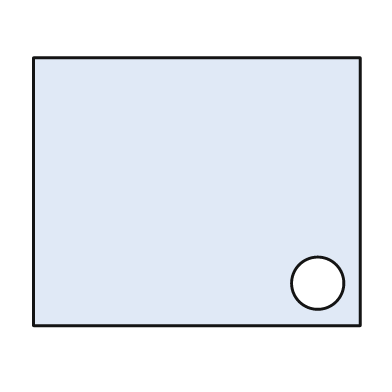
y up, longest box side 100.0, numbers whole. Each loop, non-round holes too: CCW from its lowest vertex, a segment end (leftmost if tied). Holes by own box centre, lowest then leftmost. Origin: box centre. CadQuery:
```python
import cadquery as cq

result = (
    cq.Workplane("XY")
    .moveTo(-50.0, -41.0)
    .lineTo(50.0, -41.0)
    .lineTo(50.0, 41.0)
    .lineTo(-50.0, 41.0)
    .close()
    .moveTo(37.0, -28.0)
    .circle(8.0)
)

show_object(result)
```